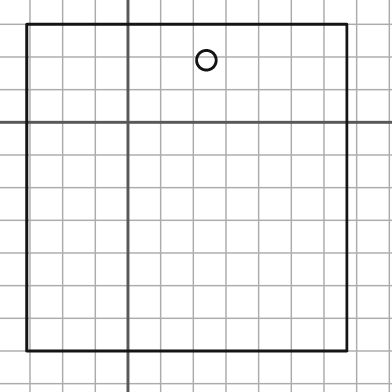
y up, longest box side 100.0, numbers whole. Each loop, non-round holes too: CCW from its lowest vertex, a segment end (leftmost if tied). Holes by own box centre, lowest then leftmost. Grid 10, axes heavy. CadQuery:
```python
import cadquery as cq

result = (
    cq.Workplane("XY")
    .moveTo(-31.0, -70.0)
    .lineTo(67.0, -70.0)
    .lineTo(67.0, 30.0)
    .lineTo(-31.0, 30.0)
    .close()
    .moveTo(24.0, 19.0)
    .circle(3.0)
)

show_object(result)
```